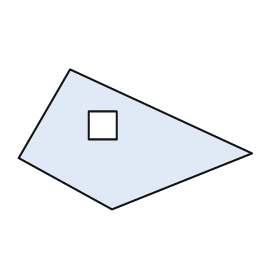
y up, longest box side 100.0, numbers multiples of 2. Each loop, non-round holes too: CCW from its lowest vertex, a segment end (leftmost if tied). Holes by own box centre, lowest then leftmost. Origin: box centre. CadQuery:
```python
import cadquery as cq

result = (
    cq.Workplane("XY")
    .moveTo(-10.0, -30.0)
    .lineTo(50.0, -6.0)
    .lineTo(-28.0, 30.0)
    .lineTo(-50.0, -8.0)
    .close()
    .moveTo(-20.0, 0.0)
    .lineTo(-8.0, 0.0)
    .lineTo(-8.0, 12.0)
    .lineTo(-20.0, 12.0)
    .close()
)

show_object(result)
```